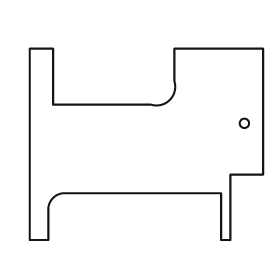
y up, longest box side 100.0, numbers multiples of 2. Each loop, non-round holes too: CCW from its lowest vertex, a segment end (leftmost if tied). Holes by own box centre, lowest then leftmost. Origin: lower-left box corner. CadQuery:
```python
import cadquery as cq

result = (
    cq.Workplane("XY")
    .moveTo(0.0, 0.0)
    .lineTo(8.0, 0.0)
    .lineTo(8.0, 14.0)
    .threePointArc((10.0, 18.0), (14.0, 20.0))
    .lineTo(82.0, 20.0)
    .lineTo(82.0, 0.0)
    .lineTo(86.0, 0.0)
    .lineTo(86.0, 28.0)
    .lineTo(100.0, 28.0)
    .lineTo(100.0, 82.0)
    .lineTo(62.0, 82.0)
    .lineTo(62.0, 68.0)
    .threePointArc((60.0, 60.0), (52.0, 58.0))
    .lineTo(10.0, 58.0)
    .lineTo(10.0, 82.0)
    .lineTo(0.0, 82.0)
    .close()
    .moveTo(92.0, 50.0)
    .circle(2.0)
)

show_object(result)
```